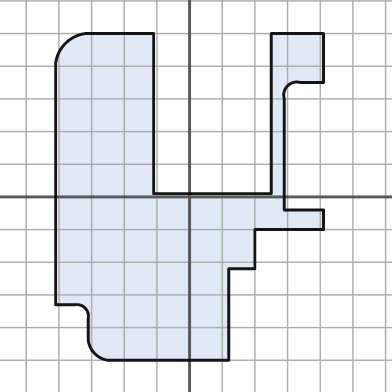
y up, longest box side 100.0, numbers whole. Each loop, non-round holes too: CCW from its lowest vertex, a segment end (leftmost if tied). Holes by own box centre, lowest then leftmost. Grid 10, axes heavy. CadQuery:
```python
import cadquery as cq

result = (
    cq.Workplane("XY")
    .moveTo(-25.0, -50.0)
    .lineTo(12.0, -50.0)
    .lineTo(12.0, -22.0)
    .lineTo(20.0, -22.0)
    .lineTo(20.0, -10.0)
    .lineTo(41.0, -10.0)
    .lineTo(41.0, -4.0)
    .lineTo(29.0, -4.0)
    .lineTo(29.0, 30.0)
    .threePointArc((30.0, 34.0), (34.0, 35.0))
    .lineTo(41.0, 35.0)
    .lineTo(41.0, 50.0)
    .lineTo(25.0, 50.0)
    .lineTo(25.0, 1.0)
    .lineTo(-11.0, 1.0)
    .lineTo(-11.0, 50.0)
    .lineTo(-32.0, 50.0)
    .threePointArc((-38.0, 47.0), (-41.0, 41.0))
    .lineTo(-41.0, -33.0)
    .lineTo(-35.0, -33.0)
    .threePointArc((-32.0, -34.0), (-31.0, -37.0))
    .lineTo(-31.0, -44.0)
    .threePointArc((-29.0, -48.0), (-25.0, -50.0))
    .close()
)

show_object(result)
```